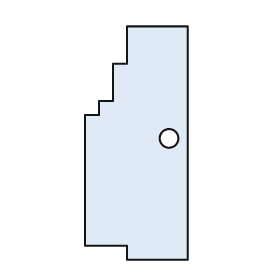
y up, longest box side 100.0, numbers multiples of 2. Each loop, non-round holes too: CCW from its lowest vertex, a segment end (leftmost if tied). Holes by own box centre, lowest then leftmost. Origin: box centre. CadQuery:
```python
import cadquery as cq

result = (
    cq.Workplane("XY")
    .moveTo(-4.0, -50.0)
    .lineTo(22.0, -50.0)
    .lineTo(22.0, 50.0)
    .lineTo(-4.0, 50.0)
    .lineTo(-4.0, 34.0)
    .lineTo(-10.0, 34.0)
    .lineTo(-10.0, 18.0)
    .lineTo(-16.0, 18.0)
    .lineTo(-16.0, 12.0)
    .lineTo(-22.0, 12.0)
    .lineTo(-22.0, -44.0)
    .lineTo(-4.0, -44.0)
    .close()
    .moveTo(14.0, 2.0)
    .circle(4.0)
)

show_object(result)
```